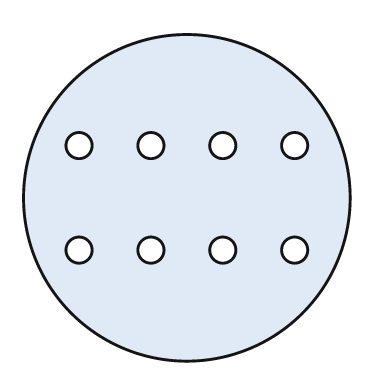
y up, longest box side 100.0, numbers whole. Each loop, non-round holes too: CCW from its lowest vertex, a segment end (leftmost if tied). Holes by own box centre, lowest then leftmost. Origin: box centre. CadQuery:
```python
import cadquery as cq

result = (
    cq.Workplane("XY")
    .moveTo(0.0, 0.0)
    .circle(50.0)
    .moveTo(-33.0, -16.0)
    .circle(4.0)
    .moveTo(-11.0, -16.0)
    .circle(4.0)
    .moveTo(11.0, -16.0)
    .circle(4.0)
    .moveTo(33.0, -16.0)
    .circle(4.0)
    .moveTo(-33.0, 16.0)
    .circle(4.0)
    .moveTo(-11.0, 16.0)
    .circle(4.0)
    .moveTo(11.0, 16.0)
    .circle(4.0)
    .moveTo(33.0, 16.0)
    .circle(4.0)
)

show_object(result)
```